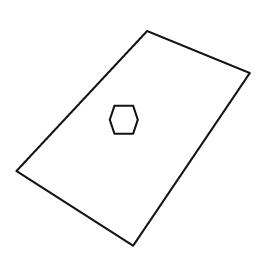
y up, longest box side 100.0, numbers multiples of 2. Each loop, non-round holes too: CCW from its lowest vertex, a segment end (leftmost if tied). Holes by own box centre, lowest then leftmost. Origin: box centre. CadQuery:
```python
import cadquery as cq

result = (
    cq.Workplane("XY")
    .moveTo(0.0, -46.0)
    .lineTo(50.0, 28.0)
    .lineTo(6.0, 46.0)
    .lineTo(-50.0, -14.0)
    .close()
    .moveTo(-8.0, 2.0)
    .lineTo(0.0, 2.0)
    .lineTo(2.0, 8.0)
    .lineTo(0.0, 14.0)
    .lineTo(-8.0, 14.0)
    .lineTo(-10.0, 8.0)
    .close()
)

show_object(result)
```